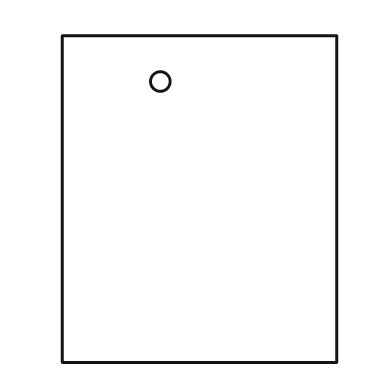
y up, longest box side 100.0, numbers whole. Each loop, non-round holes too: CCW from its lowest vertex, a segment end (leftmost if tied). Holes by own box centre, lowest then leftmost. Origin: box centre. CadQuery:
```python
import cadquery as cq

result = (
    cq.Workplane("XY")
    .moveTo(-42.0, -50.0)
    .lineTo(42.0, -50.0)
    .lineTo(42.0, 50.0)
    .lineTo(-42.0, 50.0)
    .close()
    .moveTo(-12.0, 36.0)
    .circle(3.0)
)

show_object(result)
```